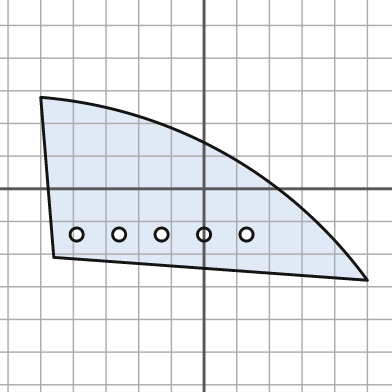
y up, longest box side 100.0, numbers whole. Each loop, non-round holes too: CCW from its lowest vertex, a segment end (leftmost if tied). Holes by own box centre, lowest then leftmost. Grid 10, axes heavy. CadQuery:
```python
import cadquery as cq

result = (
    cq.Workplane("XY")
    .moveTo(50.0, -28.0)
    .threePointArc((6.0, 11.0), (-50.0, 28.0))
    .lineTo(-46.0, -21.0)
    .close()
    .moveTo(-39.0, -14.0)
    .circle(2.0)
    .moveTo(-26.0, -14.0)
    .circle(2.0)
    .moveTo(-13.0, -14.0)
    .circle(2.0)
    .moveTo(0.0, -14.0)
    .circle(2.0)
    .moveTo(13.0, -14.0)
    .circle(2.0)
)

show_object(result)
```